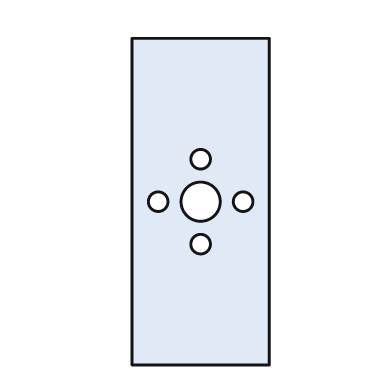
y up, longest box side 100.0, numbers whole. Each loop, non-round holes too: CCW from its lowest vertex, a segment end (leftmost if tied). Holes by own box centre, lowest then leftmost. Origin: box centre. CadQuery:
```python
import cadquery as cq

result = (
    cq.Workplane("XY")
    .moveTo(-21.0, -50.0)
    .lineTo(21.0, -50.0)
    .lineTo(21.0, 50.0)
    .lineTo(-21.0, 50.0)
    .close()
    .moveTo(0.0, -13.0)
    .circle(3.0)
    .moveTo(-13.0, 0.0)
    .circle(3.0)
    .moveTo(0.0, 0.0)
    .circle(6.0)
    .moveTo(13.0, 0.0)
    .circle(3.0)
    .moveTo(0.0, 13.0)
    .circle(3.0)
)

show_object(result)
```